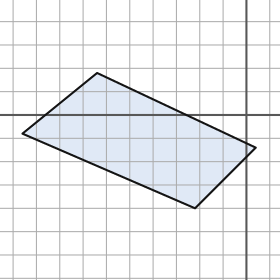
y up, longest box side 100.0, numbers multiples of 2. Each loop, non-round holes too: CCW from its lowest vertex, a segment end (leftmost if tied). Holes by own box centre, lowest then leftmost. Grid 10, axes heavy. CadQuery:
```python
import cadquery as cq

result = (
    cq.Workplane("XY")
    .moveTo(-22.0, -40.0)
    .lineTo(4.0, -14.0)
    .lineTo(-64.0, 18.0)
    .lineTo(-96.0, -8.0)
    .close()
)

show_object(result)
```